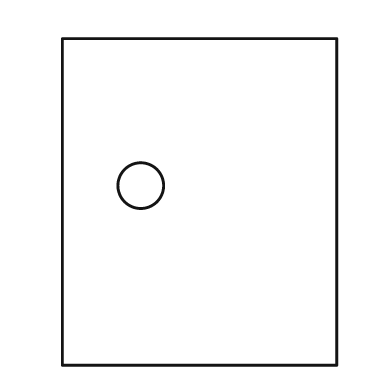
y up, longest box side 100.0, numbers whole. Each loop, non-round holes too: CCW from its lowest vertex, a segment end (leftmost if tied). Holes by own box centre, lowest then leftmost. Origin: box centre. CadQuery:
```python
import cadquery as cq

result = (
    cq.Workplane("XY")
    .moveTo(-42.0, -50.0)
    .lineTo(42.0, -50.0)
    .lineTo(42.0, 50.0)
    .lineTo(-42.0, 50.0)
    .close()
    .moveTo(-18.0, 5.0)
    .circle(7.0)
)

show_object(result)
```